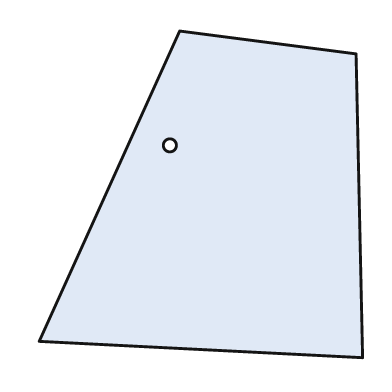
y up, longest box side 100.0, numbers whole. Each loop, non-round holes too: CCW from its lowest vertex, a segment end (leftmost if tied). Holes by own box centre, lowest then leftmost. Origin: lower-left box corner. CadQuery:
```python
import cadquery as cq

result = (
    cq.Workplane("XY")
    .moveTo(99.0, 0.0)
    .lineTo(97.0, 93.0)
    .lineTo(43.0, 100.0)
    .lineTo(0.0, 5.0)
    .close()
    .moveTo(40.0, 65.0)
    .circle(2.0)
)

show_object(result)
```